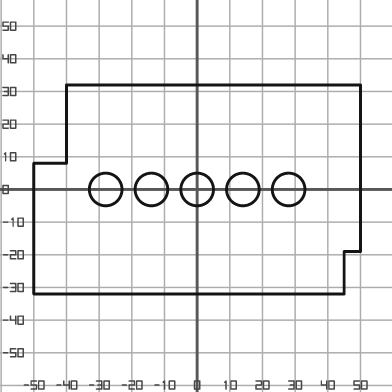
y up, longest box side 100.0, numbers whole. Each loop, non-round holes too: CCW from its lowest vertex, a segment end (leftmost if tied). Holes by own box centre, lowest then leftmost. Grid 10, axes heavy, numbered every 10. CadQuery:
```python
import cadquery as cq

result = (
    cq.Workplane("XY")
    .moveTo(-50.0, -32.0)
    .lineTo(45.0, -32.0)
    .lineTo(45.0, -19.0)
    .lineTo(50.0, -19.0)
    .lineTo(50.0, 32.0)
    .lineTo(-40.0, 32.0)
    .lineTo(-40.0, 8.0)
    .lineTo(-50.0, 8.0)
    .close()
    .moveTo(-28.0, 0.0)
    .circle(5.0)
    .moveTo(-14.0, 0.0)
    .circle(5.0)
    .moveTo(0.0, 0.0)
    .circle(5.0)
    .moveTo(14.0, 0.0)
    .circle(5.0)
    .moveTo(28.0, 0.0)
    .circle(5.0)
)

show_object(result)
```